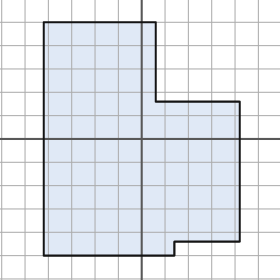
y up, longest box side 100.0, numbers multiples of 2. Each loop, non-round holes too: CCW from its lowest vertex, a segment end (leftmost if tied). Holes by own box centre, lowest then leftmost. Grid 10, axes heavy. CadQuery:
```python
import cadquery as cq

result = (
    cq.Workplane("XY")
    .moveTo(-42.0, -50.0)
    .lineTo(14.0, -50.0)
    .lineTo(14.0, -44.0)
    .lineTo(42.0, -44.0)
    .lineTo(42.0, 16.0)
    .lineTo(6.0, 16.0)
    .lineTo(6.0, 50.0)
    .lineTo(-42.0, 50.0)
    .close()
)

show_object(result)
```